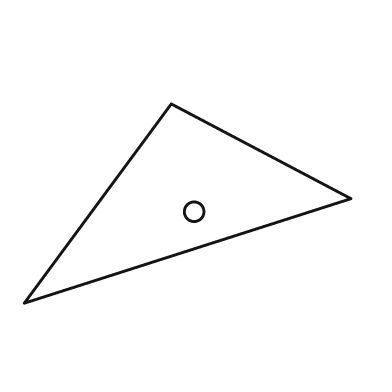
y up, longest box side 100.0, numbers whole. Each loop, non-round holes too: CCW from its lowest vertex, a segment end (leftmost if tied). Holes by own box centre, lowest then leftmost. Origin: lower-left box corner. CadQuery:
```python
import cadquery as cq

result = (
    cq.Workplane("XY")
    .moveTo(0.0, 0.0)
    .lineTo(100.0, 32.0)
    .lineTo(45.0, 61.0)
    .close()
    .moveTo(52.0, 28.0)
    .circle(3.0)
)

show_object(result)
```